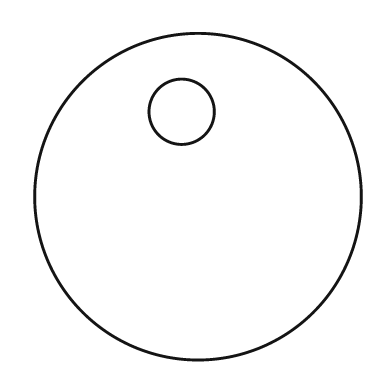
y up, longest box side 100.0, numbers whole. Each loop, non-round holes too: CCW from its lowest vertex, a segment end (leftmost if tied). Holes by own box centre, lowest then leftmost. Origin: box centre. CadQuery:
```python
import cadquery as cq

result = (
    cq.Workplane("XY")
    .moveTo(0.0, 0.0)
    .circle(50.0)
    .moveTo(-5.0, 26.0)
    .circle(10.0)
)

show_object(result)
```